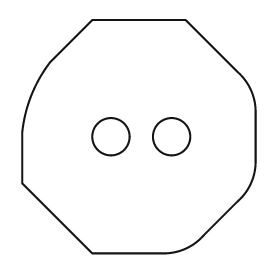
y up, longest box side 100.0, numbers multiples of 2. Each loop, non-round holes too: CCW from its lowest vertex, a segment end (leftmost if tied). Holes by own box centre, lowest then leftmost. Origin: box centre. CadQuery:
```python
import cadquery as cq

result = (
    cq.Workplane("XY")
    .moveTo(-20.0, -50.0)
    .lineTo(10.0, -50.0)
    .threePointArc((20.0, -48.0), (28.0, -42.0))
    .lineTo(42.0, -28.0)
    .threePointArc((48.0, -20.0), (50.0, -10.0))
    .lineTo(50.0, 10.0)
    .threePointArc((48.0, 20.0), (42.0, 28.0))
    .lineTo(20.0, 50.0)
    .lineTo(-20.0, 50.0)
    .lineTo(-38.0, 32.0)
    .threePointArc((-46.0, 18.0), (-50.0, 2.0))
    .lineTo(-50.0, -20.0)
    .close()
    .moveTo(-12.0, 0.0)
    .circle(8.0)
    .moveTo(14.0, 0.0)
    .circle(8.0)
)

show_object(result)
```